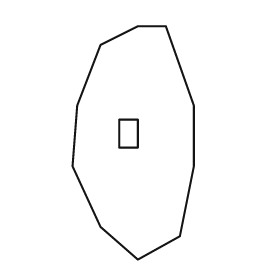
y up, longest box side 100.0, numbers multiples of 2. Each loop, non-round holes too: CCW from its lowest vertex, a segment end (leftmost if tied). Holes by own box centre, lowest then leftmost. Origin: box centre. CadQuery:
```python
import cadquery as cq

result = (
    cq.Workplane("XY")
    .moveTo(2.0, -50.0)
    .lineTo(20.0, -40.0)
    .lineTo(26.0, -10.0)
    .lineTo(26.0, 16.0)
    .lineTo(14.0, 50.0)
    .lineTo(2.0, 50.0)
    .lineTo(-14.0, 42.0)
    .lineTo(-24.0, 16.0)
    .lineTo(-26.0, -10.0)
    .lineTo(-14.0, -36.0)
    .close()
    .moveTo(-6.0, -2.0)
    .lineTo(2.0, -2.0)
    .lineTo(2.0, 10.0)
    .lineTo(-6.0, 10.0)
    .close()
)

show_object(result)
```